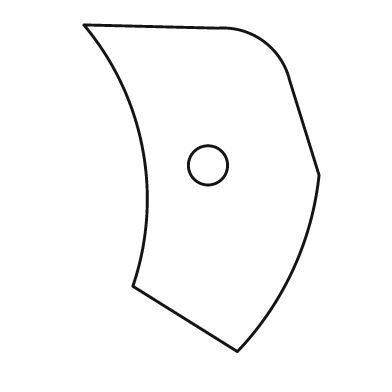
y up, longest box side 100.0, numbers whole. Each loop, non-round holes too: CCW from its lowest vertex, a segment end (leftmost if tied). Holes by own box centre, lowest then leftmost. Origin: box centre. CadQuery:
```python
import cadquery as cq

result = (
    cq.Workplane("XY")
    .moveTo(11.0, -50.0)
    .threePointArc((28.0, -25.0), (36.0, 4.0))
    .lineTo(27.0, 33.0)
    .threePointArc((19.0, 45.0), (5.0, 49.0))
    .lineTo(-36.0, 50.0)
    .threePointArc((-18.0, 12.0), (-21.0, -30.0))
    .close()
    .moveTo(2.0, 7.0)
    .circle(6.0)
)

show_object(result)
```